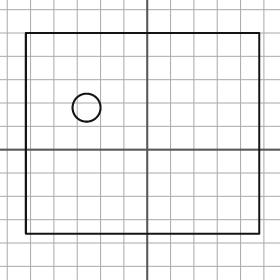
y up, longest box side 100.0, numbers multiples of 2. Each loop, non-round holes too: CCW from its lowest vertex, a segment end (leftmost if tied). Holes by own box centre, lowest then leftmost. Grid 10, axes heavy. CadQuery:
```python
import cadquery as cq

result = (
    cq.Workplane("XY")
    .moveTo(-52.0, -36.0)
    .lineTo(48.0, -36.0)
    .lineTo(48.0, 50.0)
    .lineTo(-52.0, 50.0)
    .close()
    .moveTo(-26.0, 18.0)
    .circle(6.0)
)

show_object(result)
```